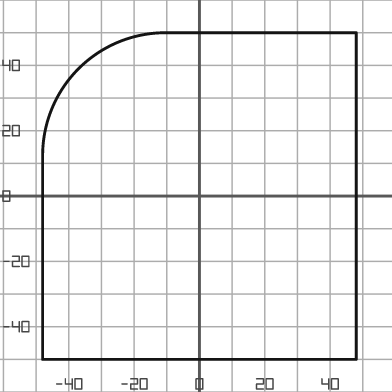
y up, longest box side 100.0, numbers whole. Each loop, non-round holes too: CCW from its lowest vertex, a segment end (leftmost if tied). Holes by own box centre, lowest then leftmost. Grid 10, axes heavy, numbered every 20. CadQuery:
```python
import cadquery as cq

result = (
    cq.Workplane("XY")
    .moveTo(-48.0, -50.0)
    .lineTo(48.0, -50.0)
    .lineTo(48.0, 50.0)
    .lineTo(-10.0, 50.0)
    .threePointArc((-37.0, 39.0), (-48.0, 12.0))
    .close()
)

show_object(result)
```